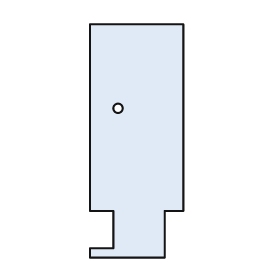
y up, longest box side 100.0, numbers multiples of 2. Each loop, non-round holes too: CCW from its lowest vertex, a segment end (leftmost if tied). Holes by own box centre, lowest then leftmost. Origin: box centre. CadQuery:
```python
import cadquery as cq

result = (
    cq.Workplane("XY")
    .moveTo(-20.0, -50.0)
    .lineTo(12.0, -50.0)
    .lineTo(12.0, -30.0)
    .lineTo(20.0, -30.0)
    .lineTo(20.0, 50.0)
    .lineTo(-20.0, 50.0)
    .lineTo(-20.0, -30.0)
    .lineTo(-10.0, -30.0)
    .lineTo(-10.0, -46.0)
    .lineTo(-20.0, -46.0)
    .close()
    .moveTo(-8.0, 14.0)
    .circle(2.0)
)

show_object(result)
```